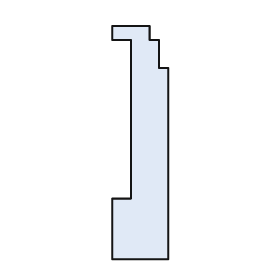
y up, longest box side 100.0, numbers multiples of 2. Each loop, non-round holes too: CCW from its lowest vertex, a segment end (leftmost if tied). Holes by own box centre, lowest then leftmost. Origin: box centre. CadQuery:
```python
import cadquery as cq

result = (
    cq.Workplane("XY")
    .moveTo(-12.0, -50.0)
    .lineTo(12.0, -50.0)
    .lineTo(12.0, 32.0)
    .lineTo(8.0, 32.0)
    .lineTo(8.0, 44.0)
    .lineTo(4.0, 44.0)
    .lineTo(4.0, 50.0)
    .lineTo(-12.0, 50.0)
    .lineTo(-12.0, 44.0)
    .lineTo(-4.0, 44.0)
    .lineTo(-4.0, -24.0)
    .lineTo(-12.0, -24.0)
    .close()
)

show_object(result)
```